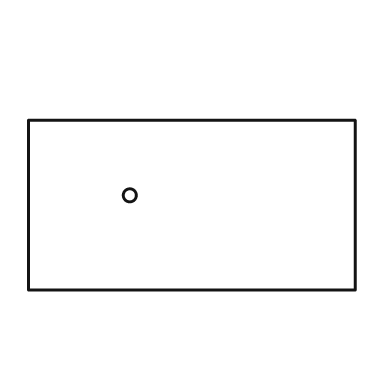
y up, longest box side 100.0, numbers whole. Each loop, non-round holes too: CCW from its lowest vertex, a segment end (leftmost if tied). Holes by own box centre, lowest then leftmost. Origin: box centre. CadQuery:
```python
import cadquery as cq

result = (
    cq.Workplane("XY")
    .moveTo(-50.0, -26.0)
    .lineTo(50.0, -26.0)
    .lineTo(50.0, 26.0)
    .lineTo(-50.0, 26.0)
    .close()
    .moveTo(-19.0, 3.0)
    .circle(2.0)
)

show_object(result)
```